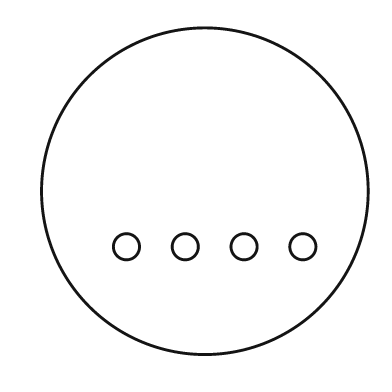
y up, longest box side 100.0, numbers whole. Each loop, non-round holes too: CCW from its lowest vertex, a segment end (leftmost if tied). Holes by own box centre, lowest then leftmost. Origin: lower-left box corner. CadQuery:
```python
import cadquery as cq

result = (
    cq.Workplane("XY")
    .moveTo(50.0, 50.0)
    .circle(50.0)
    .moveTo(26.0, 33.0)
    .circle(4.0)
    .moveTo(44.0, 33.0)
    .circle(4.0)
    .moveTo(62.0, 33.0)
    .circle(4.0)
    .moveTo(80.0, 33.0)
    .circle(4.0)
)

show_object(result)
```